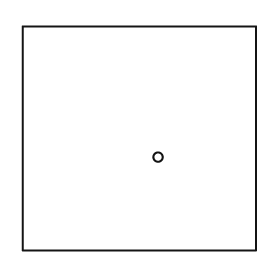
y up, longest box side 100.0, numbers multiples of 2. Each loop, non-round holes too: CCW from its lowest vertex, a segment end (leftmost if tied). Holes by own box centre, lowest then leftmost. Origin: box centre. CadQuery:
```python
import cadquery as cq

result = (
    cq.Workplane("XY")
    .moveTo(-50.0, -48.0)
    .lineTo(50.0, -48.0)
    .lineTo(50.0, 48.0)
    .lineTo(-50.0, 48.0)
    .close()
    .moveTo(8.0, -8.0)
    .circle(2.0)
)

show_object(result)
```